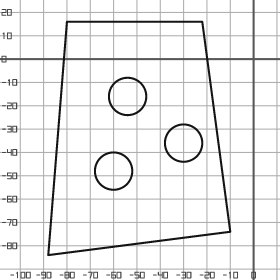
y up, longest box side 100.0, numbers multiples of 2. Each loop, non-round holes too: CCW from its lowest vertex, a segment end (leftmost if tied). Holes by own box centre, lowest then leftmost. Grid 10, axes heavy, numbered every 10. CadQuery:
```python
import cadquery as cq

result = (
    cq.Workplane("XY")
    .moveTo(-88.0, -84.0)
    .lineTo(-10.0, -74.0)
    .lineTo(-22.0, 16.0)
    .lineTo(-80.0, 16.0)
    .close()
    .moveTo(-60.0, -48.0)
    .circle(8.0)
    .moveTo(-30.0, -36.0)
    .circle(8.0)
    .moveTo(-54.0, -16.0)
    .circle(8.0)
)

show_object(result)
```